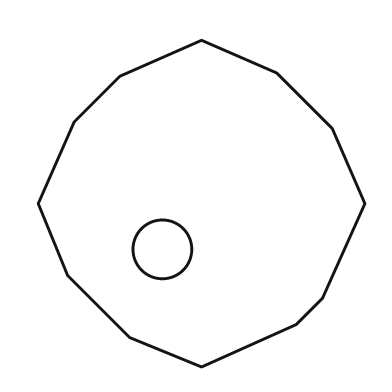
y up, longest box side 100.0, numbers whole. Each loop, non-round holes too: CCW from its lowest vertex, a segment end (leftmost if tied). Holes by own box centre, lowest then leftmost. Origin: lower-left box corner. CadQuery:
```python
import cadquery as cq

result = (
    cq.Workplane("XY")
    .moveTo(50.0, 0.0)
    .lineTo(79.0, 13.0)
    .lineTo(87.0, 21.0)
    .lineTo(100.0, 50.0)
    .lineTo(90.0, 73.0)
    .lineTo(73.0, 90.0)
    .lineTo(50.0, 100.0)
    .lineTo(25.0, 89.0)
    .lineTo(11.0, 75.0)
    .lineTo(0.0, 50.0)
    .lineTo(9.0, 28.0)
    .lineTo(28.0, 9.0)
    .close()
    .moveTo(38.0, 36.0)
    .circle(9.0)
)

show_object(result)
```